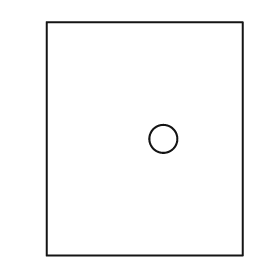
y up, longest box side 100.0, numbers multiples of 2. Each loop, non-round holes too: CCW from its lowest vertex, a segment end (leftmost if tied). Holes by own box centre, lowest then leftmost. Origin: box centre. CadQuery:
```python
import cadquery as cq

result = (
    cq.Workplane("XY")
    .moveTo(-42.0, -50.0)
    .lineTo(42.0, -50.0)
    .lineTo(42.0, 50.0)
    .lineTo(-42.0, 50.0)
    .close()
    .moveTo(8.0, 0.0)
    .circle(6.0)
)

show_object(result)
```